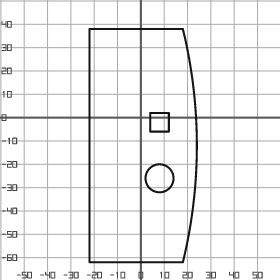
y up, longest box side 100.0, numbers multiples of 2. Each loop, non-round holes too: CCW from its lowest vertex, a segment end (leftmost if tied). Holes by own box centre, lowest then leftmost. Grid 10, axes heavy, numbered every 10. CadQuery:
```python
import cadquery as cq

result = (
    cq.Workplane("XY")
    .moveTo(-22.0, -62.0)
    .lineTo(18.0, -62.0)
    .threePointArc((24.0, -12.0), (18.0, 38.0))
    .lineTo(-22.0, 38.0)
    .close()
    .moveTo(8.0, -26.0)
    .circle(6.0)
    .moveTo(4.0, -6.0)
    .lineTo(12.0, -6.0)
    .lineTo(12.0, 2.0)
    .lineTo(4.0, 2.0)
    .close()
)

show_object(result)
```